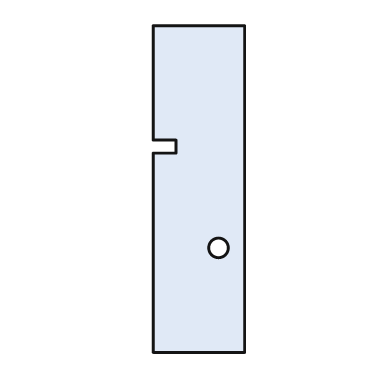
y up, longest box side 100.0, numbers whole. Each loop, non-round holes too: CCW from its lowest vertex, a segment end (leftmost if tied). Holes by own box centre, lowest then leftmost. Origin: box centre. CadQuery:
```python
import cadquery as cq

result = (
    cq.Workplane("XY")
    .moveTo(-14.0, -50.0)
    .lineTo(14.0, -50.0)
    .lineTo(14.0, 50.0)
    .lineTo(-14.0, 50.0)
    .lineTo(-14.0, 15.0)
    .lineTo(-7.0, 15.0)
    .lineTo(-7.0, 11.0)
    .lineTo(-14.0, 11.0)
    .close()
    .moveTo(6.0, -18.0)
    .circle(3.0)
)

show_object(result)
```